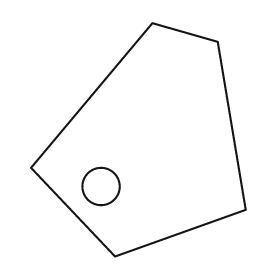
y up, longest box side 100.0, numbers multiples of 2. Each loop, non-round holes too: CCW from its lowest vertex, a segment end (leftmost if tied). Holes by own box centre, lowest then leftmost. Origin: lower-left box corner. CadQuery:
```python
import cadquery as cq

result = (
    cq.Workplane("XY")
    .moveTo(36.0, 0.0)
    .lineTo(92.0, 20.0)
    .lineTo(80.0, 92.0)
    .lineTo(52.0, 100.0)
    .lineTo(0.0, 38.0)
    .close()
    .moveTo(30.0, 30.0)
    .circle(8.0)
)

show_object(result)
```